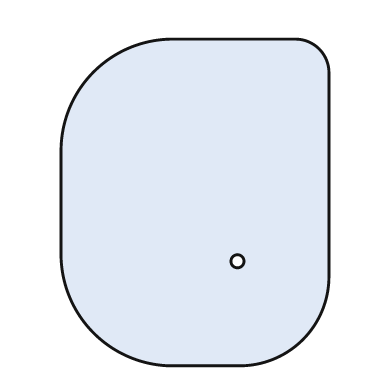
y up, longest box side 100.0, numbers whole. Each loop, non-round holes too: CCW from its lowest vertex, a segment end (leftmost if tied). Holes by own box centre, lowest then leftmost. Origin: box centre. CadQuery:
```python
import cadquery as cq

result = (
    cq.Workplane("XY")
    .moveTo(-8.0, -50.0)
    .lineTo(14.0, -50.0)
    .threePointArc((33.0, -42.0), (41.0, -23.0))
    .lineTo(41.0, 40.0)
    .threePointArc((38.0, 47.0), (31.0, 50.0))
    .lineTo(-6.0, 50.0)
    .threePointArc((-31.0, 40.0), (-41.0, 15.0))
    .lineTo(-41.0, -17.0)
    .threePointArc((-31.0, -40.0), (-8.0, -50.0))
    .close()
    .moveTo(13.0, -18.0)
    .circle(2.0)
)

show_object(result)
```